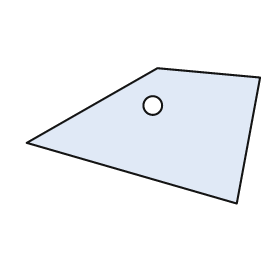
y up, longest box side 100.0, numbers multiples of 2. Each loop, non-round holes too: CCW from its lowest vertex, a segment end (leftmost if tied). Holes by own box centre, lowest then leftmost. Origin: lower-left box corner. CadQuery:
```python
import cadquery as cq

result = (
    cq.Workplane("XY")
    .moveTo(90.0, 0.0)
    .lineTo(100.0, 54.0)
    .lineTo(56.0, 58.0)
    .lineTo(0.0, 26.0)
    .close()
    .moveTo(54.0, 42.0)
    .circle(4.0)
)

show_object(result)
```